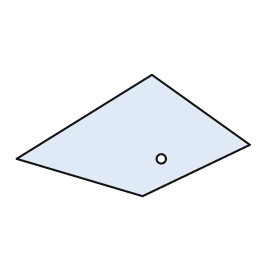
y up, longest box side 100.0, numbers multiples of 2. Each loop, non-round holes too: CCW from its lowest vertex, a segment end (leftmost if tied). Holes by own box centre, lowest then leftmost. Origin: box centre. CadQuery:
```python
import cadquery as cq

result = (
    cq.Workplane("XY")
    .moveTo(4.0, -26.0)
    .lineTo(50.0, -4.0)
    .lineTo(8.0, 26.0)
    .lineTo(-50.0, -10.0)
    .close()
    .moveTo(12.0, -10.0)
    .circle(2.0)
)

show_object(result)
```